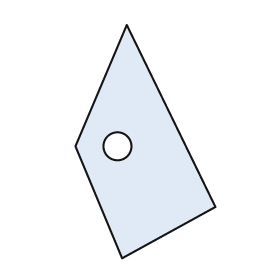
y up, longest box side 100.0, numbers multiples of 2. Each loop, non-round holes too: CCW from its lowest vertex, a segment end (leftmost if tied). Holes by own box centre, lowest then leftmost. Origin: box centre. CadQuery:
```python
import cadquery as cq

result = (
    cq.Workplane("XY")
    .moveTo(-10.0, -50.0)
    .lineTo(30.0, -28.0)
    .lineTo(-8.0, 50.0)
    .lineTo(-30.0, -2.0)
    .close()
    .moveTo(-12.0, -2.0)
    .circle(6.0)
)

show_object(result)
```